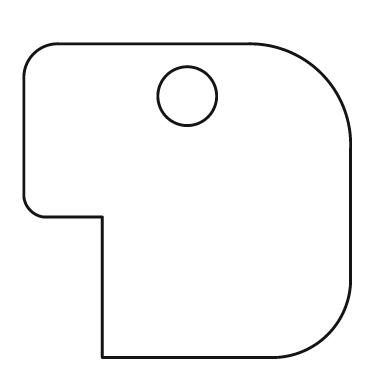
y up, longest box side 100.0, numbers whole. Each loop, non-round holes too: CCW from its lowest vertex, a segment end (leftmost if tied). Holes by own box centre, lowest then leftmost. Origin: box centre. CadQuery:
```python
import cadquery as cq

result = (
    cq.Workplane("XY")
    .moveTo(-26.0, -48.0)
    .lineTo(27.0, -48.0)
    .threePointArc((43.0, -41.0), (50.0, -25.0))
    .lineTo(50.0, 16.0)
    .threePointArc((41.0, 39.0), (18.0, 48.0))
    .lineTo(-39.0, 48.0)
    .threePointArc((-47.0, 45.0), (-50.0, 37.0))
    .lineTo(-50.0, 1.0)
    .threePointArc((-48.0, -3.0), (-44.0, -5.0))
    .lineTo(-26.0, -5.0)
    .close()
    .moveTo(0.0, 32.0)
    .circle(9.0)
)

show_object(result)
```